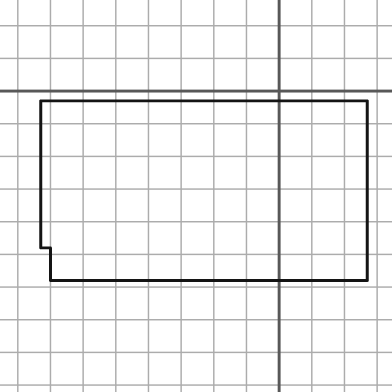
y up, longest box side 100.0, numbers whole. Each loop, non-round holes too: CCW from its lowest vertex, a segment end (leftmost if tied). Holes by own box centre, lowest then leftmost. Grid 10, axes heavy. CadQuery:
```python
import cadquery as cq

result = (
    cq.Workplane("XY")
    .moveTo(-70.0, -58.0)
    .lineTo(27.0, -58.0)
    .lineTo(27.0, -3.0)
    .lineTo(-73.0, -3.0)
    .lineTo(-73.0, -48.0)
    .lineTo(-70.0, -48.0)
    .close()
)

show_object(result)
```